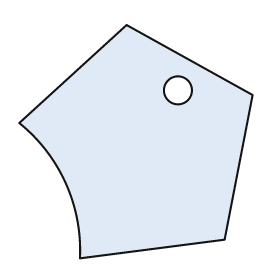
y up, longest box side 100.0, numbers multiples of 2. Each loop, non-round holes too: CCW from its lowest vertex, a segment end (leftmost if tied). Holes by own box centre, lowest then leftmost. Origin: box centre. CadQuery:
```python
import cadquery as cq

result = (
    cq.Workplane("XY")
    .moveTo(-24.0, -50.0)
    .lineTo(38.0, -42.0)
    .lineTo(50.0, 20.0)
    .lineTo(-4.0, 50.0)
    .lineTo(-50.0, 8.0)
    .threePointArc((-30.0, -18.0), (-24.0, -50.0))
    .close()
    .moveTo(18.0, 22.0)
    .circle(6.0)
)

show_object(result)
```